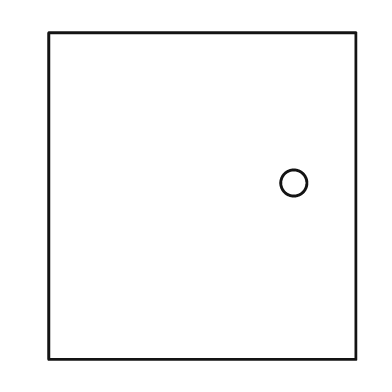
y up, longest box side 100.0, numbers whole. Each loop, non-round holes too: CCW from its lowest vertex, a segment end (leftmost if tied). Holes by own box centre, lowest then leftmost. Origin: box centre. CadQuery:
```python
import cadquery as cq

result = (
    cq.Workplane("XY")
    .moveTo(-47.0, -50.0)
    .lineTo(47.0, -50.0)
    .lineTo(47.0, 50.0)
    .lineTo(-47.0, 50.0)
    .close()
    .moveTo(28.0, 4.0)
    .circle(4.0)
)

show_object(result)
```